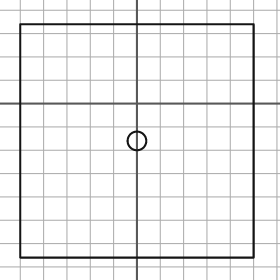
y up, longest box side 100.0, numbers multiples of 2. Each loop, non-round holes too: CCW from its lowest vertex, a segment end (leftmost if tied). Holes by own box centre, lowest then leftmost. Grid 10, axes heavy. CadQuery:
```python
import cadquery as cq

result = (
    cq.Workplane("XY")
    .moveTo(-50.0, -66.0)
    .lineTo(50.0, -66.0)
    .lineTo(50.0, 34.0)
    .lineTo(-50.0, 34.0)
    .close()
    .moveTo(0.0, -16.0)
    .circle(4.0)
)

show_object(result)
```